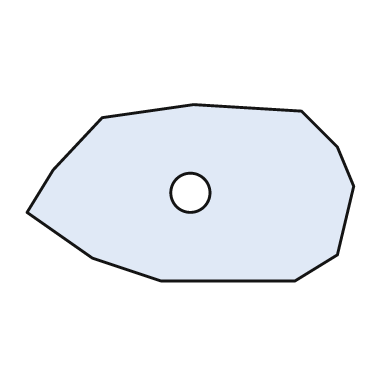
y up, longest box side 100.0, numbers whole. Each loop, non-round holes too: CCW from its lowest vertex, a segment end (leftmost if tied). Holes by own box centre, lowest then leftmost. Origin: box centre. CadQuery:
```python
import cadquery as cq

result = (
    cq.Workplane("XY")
    .moveTo(-9.0, -27.0)
    .lineTo(32.0, -27.0)
    .lineTo(45.0, -19.0)
    .lineTo(50.0, 2.0)
    .lineTo(45.0, 14.0)
    .lineTo(34.0, 25.0)
    .lineTo(1.0, 27.0)
    .lineTo(-27.0, 23.0)
    .lineTo(-42.0, 7.0)
    .lineTo(-50.0, -6.0)
    .lineTo(-30.0, -20.0)
    .close()
    .moveTo(0.0, 0.0)
    .circle(6.0)
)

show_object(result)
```